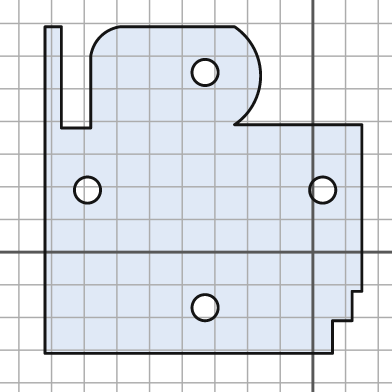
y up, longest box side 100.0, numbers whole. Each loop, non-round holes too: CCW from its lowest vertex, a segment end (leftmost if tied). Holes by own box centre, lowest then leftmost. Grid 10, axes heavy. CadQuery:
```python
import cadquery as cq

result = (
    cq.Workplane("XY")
    .moveTo(-82.0, -31.0)
    .lineTo(6.0, -31.0)
    .lineTo(6.0, -21.0)
    .lineTo(12.0, -21.0)
    .lineTo(12.0, -12.0)
    .lineTo(15.0, -12.0)
    .lineTo(15.0, 39.0)
    .lineTo(-24.0, 39.0)
    .threePointArc((-16.0, 54.0), (-24.0, 69.0))
    .lineTo(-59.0, 69.0)
    .threePointArc((-65.0, 66.0), (-68.0, 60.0))
    .lineTo(-68.0, 38.0)
    .lineTo(-77.0, 38.0)
    .lineTo(-77.0, 69.0)
    .lineTo(-82.0, 69.0)
    .close()
    .moveTo(-33.0, -17.0)
    .circle(4.0)
    .moveTo(-69.0, 19.0)
    .circle(4.0)
    .moveTo(3.0, 19.0)
    .circle(4.0)
    .moveTo(-33.0, 55.0)
    .circle(4.0)
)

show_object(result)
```